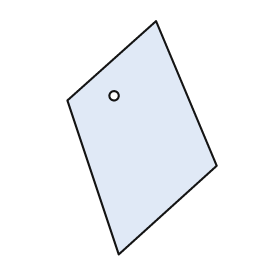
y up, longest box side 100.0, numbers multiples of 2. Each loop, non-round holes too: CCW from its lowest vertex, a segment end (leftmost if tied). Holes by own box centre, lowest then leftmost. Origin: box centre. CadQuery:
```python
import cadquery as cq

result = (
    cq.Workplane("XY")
    .moveTo(-10.0, -50.0)
    .lineTo(32.0, -12.0)
    .lineTo(6.0, 50.0)
    .lineTo(-32.0, 16.0)
    .close()
    .moveTo(-12.0, 18.0)
    .circle(2.0)
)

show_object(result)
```